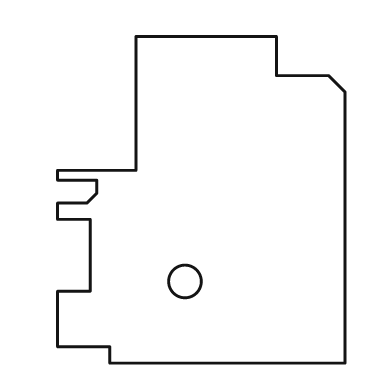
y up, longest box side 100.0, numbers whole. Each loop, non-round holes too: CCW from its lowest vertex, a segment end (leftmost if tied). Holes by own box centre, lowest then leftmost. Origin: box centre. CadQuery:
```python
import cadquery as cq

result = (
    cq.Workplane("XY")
    .moveTo(-28.0, -50.0)
    .lineTo(44.0, -50.0)
    .lineTo(44.0, 33.0)
    .lineTo(39.0, 38.0)
    .lineTo(23.0, 38.0)
    .lineTo(23.0, 50.0)
    .lineTo(-20.0, 50.0)
    .lineTo(-20.0, 9.0)
    .lineTo(-44.0, 9.0)
    .lineTo(-44.0, 6.0)
    .lineTo(-32.0, 6.0)
    .lineTo(-32.0, 2.0)
    .lineTo(-35.0, -1.0)
    .lineTo(-44.0, -1.0)
    .lineTo(-44.0, -6.0)
    .lineTo(-34.0, -6.0)
    .lineTo(-34.0, -28.0)
    .lineTo(-44.0, -28.0)
    .lineTo(-44.0, -45.0)
    .lineTo(-28.0, -45.0)
    .close()
    .moveTo(-5.0, -25.0)
    .circle(5.0)
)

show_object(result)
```